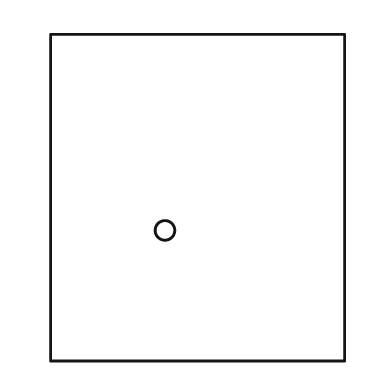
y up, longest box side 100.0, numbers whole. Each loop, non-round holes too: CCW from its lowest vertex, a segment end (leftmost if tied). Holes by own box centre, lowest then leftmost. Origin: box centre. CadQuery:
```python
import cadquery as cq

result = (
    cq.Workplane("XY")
    .moveTo(-45.0, -50.0)
    .lineTo(45.0, -50.0)
    .lineTo(45.0, 50.0)
    .lineTo(-45.0, 50.0)
    .close()
    .moveTo(-10.0, -10.0)
    .circle(3.0)
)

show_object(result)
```